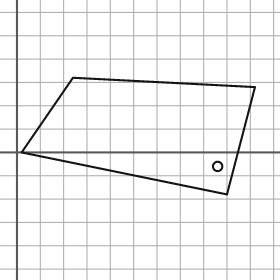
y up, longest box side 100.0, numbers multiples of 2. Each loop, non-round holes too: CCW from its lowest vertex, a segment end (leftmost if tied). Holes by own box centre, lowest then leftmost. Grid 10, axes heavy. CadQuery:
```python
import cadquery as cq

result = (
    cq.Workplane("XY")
    .moveTo(90.0, -18.0)
    .lineTo(102.0, 28.0)
    .lineTo(24.0, 32.0)
    .lineTo(2.0, 0.0)
    .close()
    .moveTo(86.0, -6.0)
    .circle(2.0)
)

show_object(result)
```